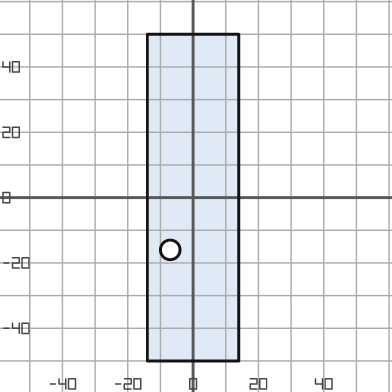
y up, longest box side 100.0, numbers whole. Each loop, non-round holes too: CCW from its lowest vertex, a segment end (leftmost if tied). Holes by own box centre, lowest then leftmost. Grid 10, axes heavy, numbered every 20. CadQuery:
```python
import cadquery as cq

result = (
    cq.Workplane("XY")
    .moveTo(-14.0, -50.0)
    .lineTo(14.0, -50.0)
    .lineTo(14.0, 50.0)
    .lineTo(-14.0, 50.0)
    .close()
    .moveTo(-7.0, -16.0)
    .circle(3.0)
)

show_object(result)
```